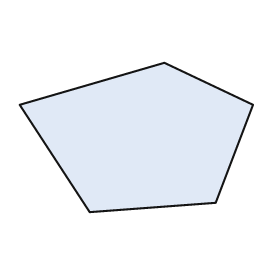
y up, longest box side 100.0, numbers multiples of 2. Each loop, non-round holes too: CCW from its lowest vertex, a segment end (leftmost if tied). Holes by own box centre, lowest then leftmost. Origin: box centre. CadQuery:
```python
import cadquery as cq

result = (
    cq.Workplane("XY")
    .moveTo(-20.0, -32.0)
    .lineTo(34.0, -28.0)
    .lineTo(50.0, 14.0)
    .lineTo(12.0, 32.0)
    .lineTo(-50.0, 14.0)
    .close()
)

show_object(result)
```